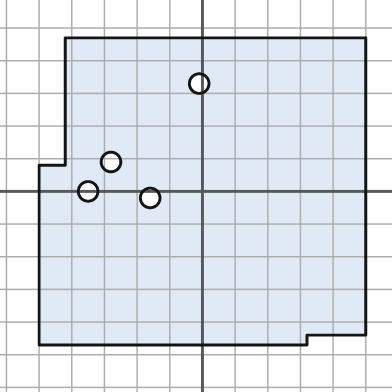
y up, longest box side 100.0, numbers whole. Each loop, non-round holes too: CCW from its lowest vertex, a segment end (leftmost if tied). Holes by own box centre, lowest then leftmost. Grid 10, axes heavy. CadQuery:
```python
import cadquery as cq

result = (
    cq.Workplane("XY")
    .moveTo(-50.0, -47.0)
    .lineTo(32.0, -47.0)
    .lineTo(32.0, -44.0)
    .lineTo(50.0, -44.0)
    .lineTo(50.0, 47.0)
    .lineTo(-42.0, 47.0)
    .lineTo(-42.0, 8.0)
    .lineTo(-50.0, 8.0)
    .close()
    .moveTo(-16.0, -2.0)
    .circle(3.0)
    .moveTo(-35.0, 0.0)
    .circle(3.0)
    .moveTo(-28.0, 9.0)
    .circle(3.0)
    .moveTo(-1.0, 33.0)
    .circle(3.0)
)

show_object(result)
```